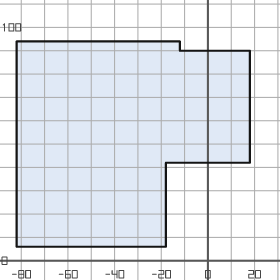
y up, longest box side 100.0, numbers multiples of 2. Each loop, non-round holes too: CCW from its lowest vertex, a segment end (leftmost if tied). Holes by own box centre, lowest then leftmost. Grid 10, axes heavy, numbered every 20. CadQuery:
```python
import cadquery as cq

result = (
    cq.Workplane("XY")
    .moveTo(-82.0, 6.0)
    .lineTo(-18.0, 6.0)
    .lineTo(-18.0, 42.0)
    .lineTo(18.0, 42.0)
    .lineTo(18.0, 90.0)
    .lineTo(-12.0, 90.0)
    .lineTo(-12.0, 94.0)
    .lineTo(-82.0, 94.0)
    .close()
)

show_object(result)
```